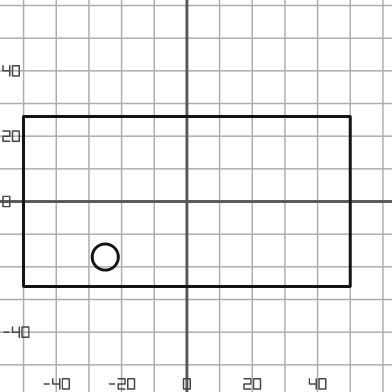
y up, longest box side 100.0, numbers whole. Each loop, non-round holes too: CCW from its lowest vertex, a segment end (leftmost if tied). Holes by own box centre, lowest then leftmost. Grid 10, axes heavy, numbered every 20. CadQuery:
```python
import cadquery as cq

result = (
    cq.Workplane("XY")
    .moveTo(-50.0, -26.0)
    .lineTo(50.0, -26.0)
    .lineTo(50.0, 26.0)
    .lineTo(-50.0, 26.0)
    .close()
    .moveTo(-25.0, -17.0)
    .circle(4.0)
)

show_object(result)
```